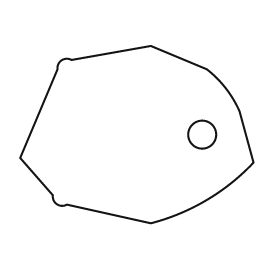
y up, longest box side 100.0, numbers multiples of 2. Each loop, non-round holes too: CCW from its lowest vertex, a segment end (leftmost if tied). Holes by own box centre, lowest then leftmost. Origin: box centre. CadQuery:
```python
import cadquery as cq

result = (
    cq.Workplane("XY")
    .moveTo(6.0, -38.0)
    .threePointArc((30.0, -28.0), (50.0, -12.0))
    .lineTo(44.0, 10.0)
    .threePointArc((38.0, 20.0), (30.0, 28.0))
    .lineTo(6.0, 38.0)
    .lineTo(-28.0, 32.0)
    .threePointArc((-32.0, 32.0), (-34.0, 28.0))
    .lineTo(-50.0, -10.0)
    .lineTo(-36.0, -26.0)
    .threePointArc((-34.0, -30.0), (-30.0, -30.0))
    .close()
    .moveTo(28.0, 0.0)
    .circle(6.0)
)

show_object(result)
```